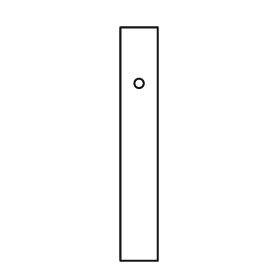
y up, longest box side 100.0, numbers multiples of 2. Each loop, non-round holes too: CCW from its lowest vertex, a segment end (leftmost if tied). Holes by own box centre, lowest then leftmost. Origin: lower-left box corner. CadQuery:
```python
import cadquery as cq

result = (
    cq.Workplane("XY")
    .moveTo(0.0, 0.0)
    .lineTo(16.0, 0.0)
    .lineTo(16.0, 100.0)
    .lineTo(0.0, 100.0)
    .close()
    .moveTo(8.0, 76.0)
    .circle(2.0)
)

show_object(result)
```